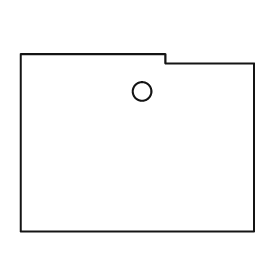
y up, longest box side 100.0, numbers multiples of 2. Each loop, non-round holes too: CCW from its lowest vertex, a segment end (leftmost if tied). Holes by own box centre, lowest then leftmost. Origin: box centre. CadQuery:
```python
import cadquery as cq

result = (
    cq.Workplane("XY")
    .moveTo(-50.0, -38.0)
    .lineTo(50.0, -38.0)
    .lineTo(50.0, 34.0)
    .lineTo(12.0, 34.0)
    .lineTo(12.0, 38.0)
    .lineTo(-50.0, 38.0)
    .close()
    .moveTo(2.0, 22.0)
    .circle(4.0)
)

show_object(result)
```